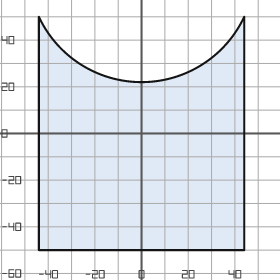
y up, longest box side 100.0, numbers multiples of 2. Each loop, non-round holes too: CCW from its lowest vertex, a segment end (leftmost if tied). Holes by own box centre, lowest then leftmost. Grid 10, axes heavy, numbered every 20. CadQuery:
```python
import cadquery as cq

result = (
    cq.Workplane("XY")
    .moveTo(-44.0, -50.0)
    .lineTo(44.0, -50.0)
    .lineTo(44.0, 50.0)
    .threePointArc((0.0, 22.0), (-44.0, 50.0))
    .close()
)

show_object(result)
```